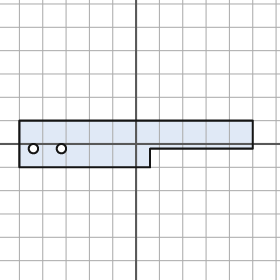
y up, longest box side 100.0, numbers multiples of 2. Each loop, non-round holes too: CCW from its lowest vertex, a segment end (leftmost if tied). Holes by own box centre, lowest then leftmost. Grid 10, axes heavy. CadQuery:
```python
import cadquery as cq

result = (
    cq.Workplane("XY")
    .moveTo(-50.0, -10.0)
    .lineTo(6.0, -10.0)
    .lineTo(6.0, -2.0)
    .lineTo(50.0, -2.0)
    .lineTo(50.0, 10.0)
    .lineTo(-50.0, 10.0)
    .close()
    .moveTo(-44.0, -2.0)
    .circle(2.0)
    .moveTo(-32.0, -2.0)
    .circle(2.0)
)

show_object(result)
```